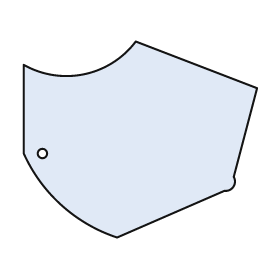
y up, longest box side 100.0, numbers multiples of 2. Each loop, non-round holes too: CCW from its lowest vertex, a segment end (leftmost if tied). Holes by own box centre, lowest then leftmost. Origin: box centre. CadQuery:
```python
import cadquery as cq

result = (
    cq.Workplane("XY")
    .moveTo(-10.0, -42.0)
    .lineTo(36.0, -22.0)
    .threePointArc((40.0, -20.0), (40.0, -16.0))
    .lineTo(50.0, 22.0)
    .lineTo(-2.0, 42.0)
    .threePointArc((-24.0, 28.0), (-50.0, 32.0))
    .lineTo(-50.0, -6.0)
    .threePointArc((-34.0, -28.0), (-10.0, -42.0))
    .close()
    .moveTo(-42.0, -6.0)
    .circle(2.0)
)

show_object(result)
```